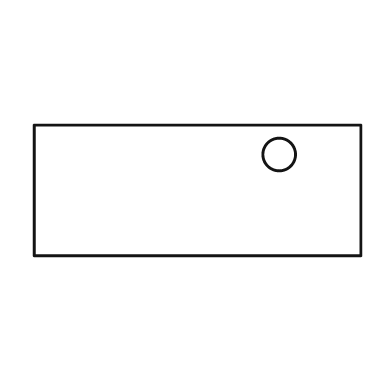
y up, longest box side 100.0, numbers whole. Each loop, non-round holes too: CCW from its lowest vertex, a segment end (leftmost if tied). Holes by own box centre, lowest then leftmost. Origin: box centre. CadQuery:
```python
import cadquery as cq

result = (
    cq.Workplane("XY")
    .moveTo(-50.0, -20.0)
    .lineTo(50.0, -20.0)
    .lineTo(50.0, 20.0)
    .lineTo(-50.0, 20.0)
    .close()
    .moveTo(25.0, 11.0)
    .circle(5.0)
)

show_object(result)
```